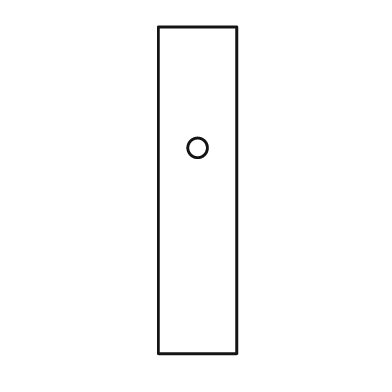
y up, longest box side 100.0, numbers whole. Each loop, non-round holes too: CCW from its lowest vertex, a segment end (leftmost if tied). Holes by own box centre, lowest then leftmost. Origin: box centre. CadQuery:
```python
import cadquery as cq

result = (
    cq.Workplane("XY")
    .moveTo(-12.0, -50.0)
    .lineTo(12.0, -50.0)
    .lineTo(12.0, 50.0)
    .lineTo(-12.0, 50.0)
    .close()
    .moveTo(0.0, 13.0)
    .circle(3.0)
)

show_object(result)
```